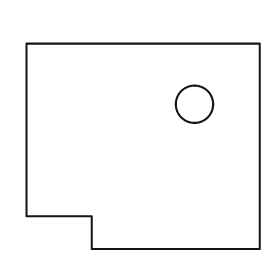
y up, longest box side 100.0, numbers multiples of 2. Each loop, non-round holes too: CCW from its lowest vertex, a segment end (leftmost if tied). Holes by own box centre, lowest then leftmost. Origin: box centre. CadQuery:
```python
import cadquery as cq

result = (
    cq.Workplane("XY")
    .moveTo(-22.0, -44.0)
    .lineTo(50.0, -44.0)
    .lineTo(50.0, 44.0)
    .lineTo(-50.0, 44.0)
    .lineTo(-50.0, -30.0)
    .lineTo(-22.0, -30.0)
    .close()
    .moveTo(22.0, 18.0)
    .circle(8.0)
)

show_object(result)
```